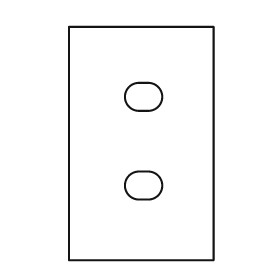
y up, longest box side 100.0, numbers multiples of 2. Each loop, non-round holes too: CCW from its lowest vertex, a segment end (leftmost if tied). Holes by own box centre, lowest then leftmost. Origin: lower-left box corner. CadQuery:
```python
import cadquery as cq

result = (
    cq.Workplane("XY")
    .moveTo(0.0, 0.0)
    .lineTo(62.0, 0.0)
    .lineTo(62.0, 100.0)
    .lineTo(0.0, 100.0)
    .close()
    .moveTo(30.0, 26.0)
    .lineTo(34.0, 26.0)
    .threePointArc((40.0, 32.0), (34.0, 38.0))
    .lineTo(30.0, 38.0)
    .threePointArc((24.0, 32.0), (30.0, 26.0))
    .close()
    .moveTo(30.0, 64.0)
    .lineTo(34.0, 64.0)
    .threePointArc((40.0, 70.0), (34.0, 76.0))
    .lineTo(30.0, 76.0)
    .threePointArc((24.0, 70.0), (30.0, 64.0))
    .close()
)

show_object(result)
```